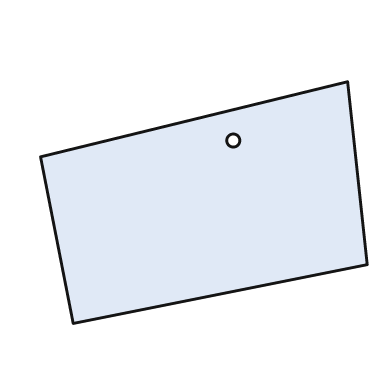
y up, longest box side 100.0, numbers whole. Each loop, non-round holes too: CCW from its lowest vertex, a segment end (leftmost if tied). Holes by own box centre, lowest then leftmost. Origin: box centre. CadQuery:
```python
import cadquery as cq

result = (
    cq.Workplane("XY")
    .moveTo(-40.0, -37.0)
    .lineTo(50.0, -19.0)
    .lineTo(44.0, 37.0)
    .lineTo(-50.0, 14.0)
    .close()
    .moveTo(9.0, 19.0)
    .circle(2.0)
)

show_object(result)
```